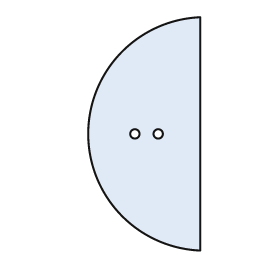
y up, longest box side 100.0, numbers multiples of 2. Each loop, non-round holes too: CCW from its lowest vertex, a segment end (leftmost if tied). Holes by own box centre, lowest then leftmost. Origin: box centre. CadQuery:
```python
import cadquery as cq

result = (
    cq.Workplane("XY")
    .moveTo(24.0, -50.0)
    .lineTo(24.0, 50.0)
    .threePointArc((-24.0, 0.0), (24.0, -50.0))
    .close()
    .moveTo(-4.0, 0.0)
    .circle(2.0)
    .moveTo(6.0, 0.0)
    .circle(2.0)
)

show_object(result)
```